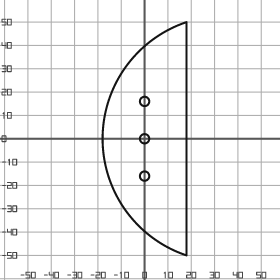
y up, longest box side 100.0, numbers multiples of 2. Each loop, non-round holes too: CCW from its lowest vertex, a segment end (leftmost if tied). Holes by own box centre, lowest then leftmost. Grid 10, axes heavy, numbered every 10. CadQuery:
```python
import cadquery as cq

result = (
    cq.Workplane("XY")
    .moveTo(18.0, -50.0)
    .lineTo(18.0, 50.0)
    .threePointArc((-18.0, 0.0), (18.0, -50.0))
    .close()
    .moveTo(0.0, -16.0)
    .circle(2.0)
    .moveTo(0.0, 0.0)
    .circle(2.0)
    .moveTo(0.0, 16.0)
    .circle(2.0)
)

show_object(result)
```